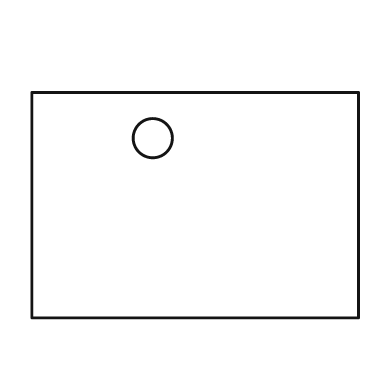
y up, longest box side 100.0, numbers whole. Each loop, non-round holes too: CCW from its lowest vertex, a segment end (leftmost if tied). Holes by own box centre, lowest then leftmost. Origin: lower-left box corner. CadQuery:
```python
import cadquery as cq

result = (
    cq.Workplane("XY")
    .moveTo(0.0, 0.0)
    .lineTo(100.0, 0.0)
    .lineTo(100.0, 69.0)
    .lineTo(0.0, 69.0)
    .close()
    .moveTo(37.0, 55.0)
    .circle(6.0)
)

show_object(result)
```